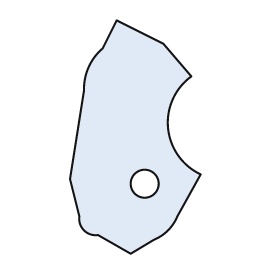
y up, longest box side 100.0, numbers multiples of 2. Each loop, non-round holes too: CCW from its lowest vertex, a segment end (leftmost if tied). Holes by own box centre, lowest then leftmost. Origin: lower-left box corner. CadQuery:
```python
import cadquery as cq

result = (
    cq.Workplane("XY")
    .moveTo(26.0, 0.0)
    .lineTo(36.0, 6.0)
    .threePointArc((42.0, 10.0), (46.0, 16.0))
    .lineTo(56.0, 34.0)
    .threePointArc((42.0, 54.0), (52.0, 76.0))
    .lineTo(40.0, 90.0)
    .lineTo(20.0, 100.0)
    .lineTo(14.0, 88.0)
    .threePointArc((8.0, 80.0), (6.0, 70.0))
    .lineTo(0.0, 32.0)
    .lineTo(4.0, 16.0)
    .threePointArc((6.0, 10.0), (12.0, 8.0))
    .close()
    .moveTo(32.0, 30.0)
    .circle(6.0)
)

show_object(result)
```